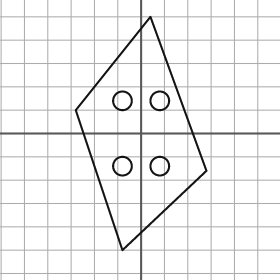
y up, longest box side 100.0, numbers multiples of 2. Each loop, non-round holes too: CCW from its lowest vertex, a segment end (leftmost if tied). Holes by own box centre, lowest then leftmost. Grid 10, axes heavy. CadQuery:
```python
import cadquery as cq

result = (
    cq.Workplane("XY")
    .moveTo(-8.0, -50.0)
    .lineTo(28.0, -16.0)
    .lineTo(4.0, 50.0)
    .lineTo(-28.0, 10.0)
    .close()
    .moveTo(-8.0, -14.0)
    .circle(4.0)
    .moveTo(8.0, -14.0)
    .circle(4.0)
    .moveTo(-8.0, 14.0)
    .circle(4.0)
    .moveTo(8.0, 14.0)
    .circle(4.0)
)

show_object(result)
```